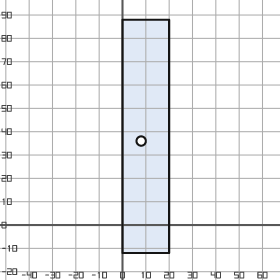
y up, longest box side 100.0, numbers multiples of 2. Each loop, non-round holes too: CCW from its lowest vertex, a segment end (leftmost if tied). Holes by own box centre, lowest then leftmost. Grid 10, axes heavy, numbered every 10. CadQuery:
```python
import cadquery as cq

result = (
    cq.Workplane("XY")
    .moveTo(0.0, -12.0)
    .lineTo(20.0, -12.0)
    .lineTo(20.0, 88.0)
    .lineTo(0.0, 88.0)
    .close()
    .moveTo(8.0, 36.0)
    .circle(2.0)
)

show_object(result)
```